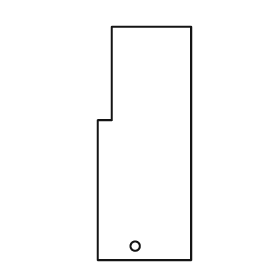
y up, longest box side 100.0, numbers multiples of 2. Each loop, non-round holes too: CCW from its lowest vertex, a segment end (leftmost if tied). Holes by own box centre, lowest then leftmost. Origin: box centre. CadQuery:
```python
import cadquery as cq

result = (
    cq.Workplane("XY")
    .moveTo(-20.0, -50.0)
    .lineTo(20.0, -50.0)
    .lineTo(20.0, 50.0)
    .lineTo(-14.0, 50.0)
    .lineTo(-14.0, 10.0)
    .lineTo(-20.0, 10.0)
    .close()
    .moveTo(-4.0, -44.0)
    .circle(2.0)
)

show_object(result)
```